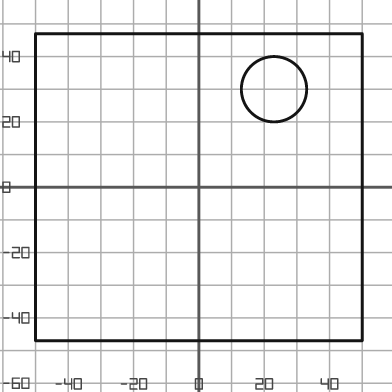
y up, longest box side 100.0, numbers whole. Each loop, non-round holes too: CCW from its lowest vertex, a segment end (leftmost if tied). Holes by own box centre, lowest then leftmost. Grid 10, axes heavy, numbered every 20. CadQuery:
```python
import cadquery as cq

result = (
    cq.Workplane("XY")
    .moveTo(-50.0, -47.0)
    .lineTo(50.0, -47.0)
    .lineTo(50.0, 47.0)
    .lineTo(-50.0, 47.0)
    .close()
    .moveTo(23.0, 30.0)
    .circle(10.0)
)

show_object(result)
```